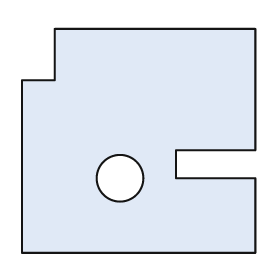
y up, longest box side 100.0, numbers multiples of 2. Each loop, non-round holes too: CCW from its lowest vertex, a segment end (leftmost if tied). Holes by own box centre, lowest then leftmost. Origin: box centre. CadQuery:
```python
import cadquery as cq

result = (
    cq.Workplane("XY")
    .moveTo(-50.0, -48.0)
    .lineTo(50.0, -48.0)
    .lineTo(50.0, -16.0)
    .lineTo(16.0, -16.0)
    .lineTo(16.0, -4.0)
    .lineTo(50.0, -4.0)
    .lineTo(50.0, 48.0)
    .lineTo(-36.0, 48.0)
    .lineTo(-36.0, 26.0)
    .lineTo(-50.0, 26.0)
    .close()
    .moveTo(-8.0, -16.0)
    .circle(10.0)
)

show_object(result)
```